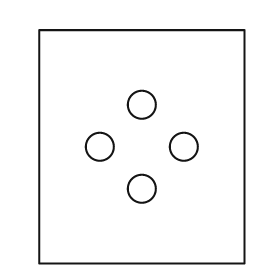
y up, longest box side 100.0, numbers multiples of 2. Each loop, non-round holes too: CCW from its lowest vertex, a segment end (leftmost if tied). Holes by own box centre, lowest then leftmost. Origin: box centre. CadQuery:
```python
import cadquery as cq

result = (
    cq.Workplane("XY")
    .moveTo(-44.0, -50.0)
    .lineTo(44.0, -50.0)
    .lineTo(44.0, 50.0)
    .lineTo(-44.0, 50.0)
    .close()
    .moveTo(0.0, -18.0)
    .circle(6.0)
    .moveTo(-18.0, 0.0)
    .circle(6.0)
    .moveTo(18.0, 0.0)
    .circle(6.0)
    .moveTo(0.0, 18.0)
    .circle(6.0)
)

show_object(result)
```